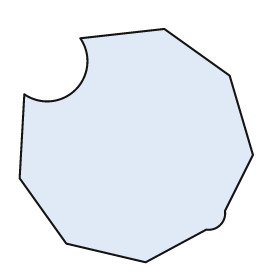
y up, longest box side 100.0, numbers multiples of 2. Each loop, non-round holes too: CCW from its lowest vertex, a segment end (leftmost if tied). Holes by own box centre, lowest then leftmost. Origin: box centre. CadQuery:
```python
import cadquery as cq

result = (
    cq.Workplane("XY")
    .moveTo(4.0, -50.0)
    .lineTo(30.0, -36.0)
    .threePointArc((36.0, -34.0), (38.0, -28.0))
    .lineTo(50.0, -4.0)
    .lineTo(40.0, 30.0)
    .lineTo(12.0, 50.0)
    .lineTo(-24.0, 46.0)
    .threePointArc((-26.0, 24.0), (-48.0, 22.0))
    .lineTo(-50.0, -14.0)
    .lineTo(-30.0, -42.0)
    .close()
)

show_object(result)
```